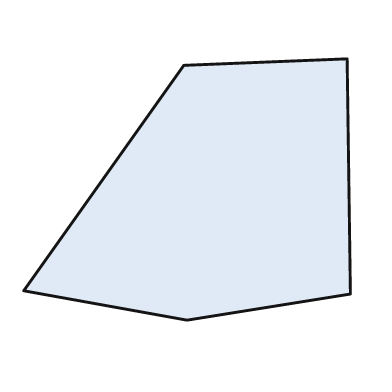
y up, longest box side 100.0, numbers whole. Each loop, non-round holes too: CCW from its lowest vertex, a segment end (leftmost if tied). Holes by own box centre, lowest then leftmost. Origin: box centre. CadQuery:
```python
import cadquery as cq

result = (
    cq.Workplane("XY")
    .moveTo(0.0, -40.0)
    .lineTo(50.0, -32.0)
    .lineTo(49.0, 40.0)
    .lineTo(-1.0, 38.0)
    .lineTo(-50.0, -31.0)
    .close()
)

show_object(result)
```